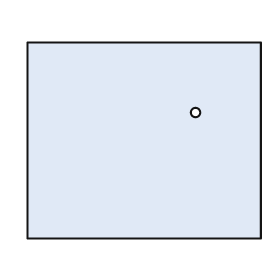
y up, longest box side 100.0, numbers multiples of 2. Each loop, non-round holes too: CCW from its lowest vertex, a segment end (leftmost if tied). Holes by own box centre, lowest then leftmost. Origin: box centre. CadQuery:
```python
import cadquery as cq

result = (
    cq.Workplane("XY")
    .moveTo(-50.0, -42.0)
    .lineTo(50.0, -42.0)
    .lineTo(50.0, 42.0)
    .lineTo(-50.0, 42.0)
    .close()
    .moveTo(22.0, 12.0)
    .circle(2.0)
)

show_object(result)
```